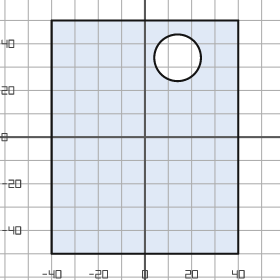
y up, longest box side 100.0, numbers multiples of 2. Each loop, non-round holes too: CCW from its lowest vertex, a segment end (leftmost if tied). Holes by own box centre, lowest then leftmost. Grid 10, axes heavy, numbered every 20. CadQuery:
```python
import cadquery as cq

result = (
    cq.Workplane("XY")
    .moveTo(-40.0, -50.0)
    .lineTo(40.0, -50.0)
    .lineTo(40.0, 50.0)
    .lineTo(-40.0, 50.0)
    .close()
    .moveTo(14.0, 34.0)
    .circle(10.0)
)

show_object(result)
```